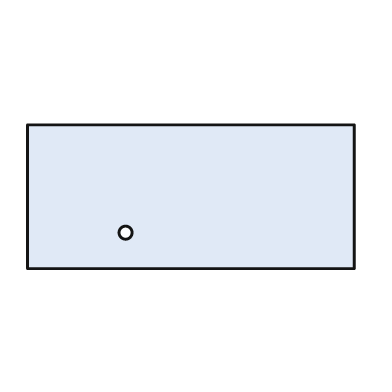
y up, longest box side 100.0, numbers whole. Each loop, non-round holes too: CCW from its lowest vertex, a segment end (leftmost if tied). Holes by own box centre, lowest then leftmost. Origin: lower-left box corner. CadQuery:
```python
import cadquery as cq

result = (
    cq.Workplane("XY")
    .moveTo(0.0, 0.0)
    .lineTo(100.0, 0.0)
    .lineTo(100.0, 44.0)
    .lineTo(0.0, 44.0)
    .close()
    .moveTo(30.0, 11.0)
    .circle(2.0)
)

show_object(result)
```